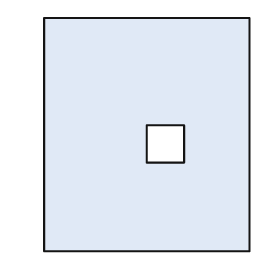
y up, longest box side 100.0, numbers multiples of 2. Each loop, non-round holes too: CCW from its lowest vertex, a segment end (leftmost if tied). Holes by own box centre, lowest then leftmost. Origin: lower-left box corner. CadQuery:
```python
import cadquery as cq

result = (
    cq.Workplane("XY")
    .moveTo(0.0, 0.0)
    .lineTo(88.0, 0.0)
    .lineTo(88.0, 100.0)
    .lineTo(0.0, 100.0)
    .close()
    .moveTo(44.0, 38.0)
    .lineTo(60.0, 38.0)
    .lineTo(60.0, 54.0)
    .lineTo(44.0, 54.0)
    .close()
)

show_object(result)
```